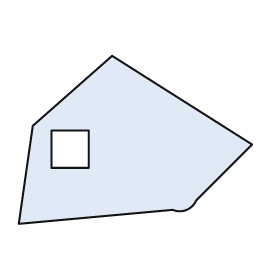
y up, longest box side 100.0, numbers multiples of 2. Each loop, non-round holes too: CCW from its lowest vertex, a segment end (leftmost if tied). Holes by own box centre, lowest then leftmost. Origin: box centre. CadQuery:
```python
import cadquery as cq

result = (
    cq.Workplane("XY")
    .moveTo(-50.0, -36.0)
    .lineTo(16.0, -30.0)
    .threePointArc((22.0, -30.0), (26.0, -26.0))
    .lineTo(50.0, -2.0)
    .lineTo(-10.0, 36.0)
    .lineTo(-44.0, 6.0)
    .close()
    .moveTo(-36.0, -12.0)
    .lineTo(-20.0, -12.0)
    .lineTo(-20.0, 4.0)
    .lineTo(-36.0, 4.0)
    .close()
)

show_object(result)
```